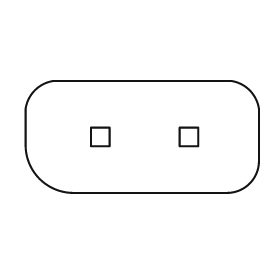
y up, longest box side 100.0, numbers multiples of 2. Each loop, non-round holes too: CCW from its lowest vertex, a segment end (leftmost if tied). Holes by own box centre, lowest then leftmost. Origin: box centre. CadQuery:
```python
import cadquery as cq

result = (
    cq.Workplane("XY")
    .moveTo(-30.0, -24.0)
    .lineTo(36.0, -24.0)
    .threePointArc((46.0, -20.0), (50.0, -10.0))
    .lineTo(50.0, 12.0)
    .threePointArc((46.0, 20.0), (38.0, 24.0))
    .lineTo(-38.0, 24.0)
    .threePointArc((-46.0, 20.0), (-50.0, 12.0))
    .lineTo(-50.0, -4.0)
    .threePointArc((-44.0, -18.0), (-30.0, -24.0))
    .close()
    .moveTo(-22.0, -4.0)
    .lineTo(-14.0, -4.0)
    .lineTo(-14.0, 4.0)
    .lineTo(-22.0, 4.0)
    .close()
    .moveTo(16.0, -4.0)
    .lineTo(24.0, -4.0)
    .lineTo(24.0, 4.0)
    .lineTo(16.0, 4.0)
    .close()
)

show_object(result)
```